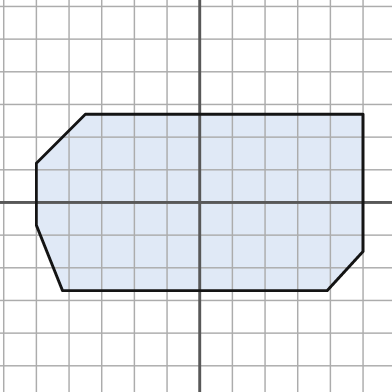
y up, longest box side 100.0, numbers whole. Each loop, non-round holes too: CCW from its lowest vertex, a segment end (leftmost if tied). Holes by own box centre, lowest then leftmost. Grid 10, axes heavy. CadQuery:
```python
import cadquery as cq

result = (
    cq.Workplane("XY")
    .moveTo(-42.0, -27.0)
    .lineTo(39.0, -27.0)
    .lineTo(50.0, -15.0)
    .lineTo(50.0, 27.0)
    .lineTo(-35.0, 27.0)
    .lineTo(-50.0, 12.0)
    .lineTo(-50.0, -7.0)
    .close()
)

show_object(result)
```